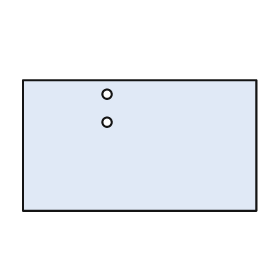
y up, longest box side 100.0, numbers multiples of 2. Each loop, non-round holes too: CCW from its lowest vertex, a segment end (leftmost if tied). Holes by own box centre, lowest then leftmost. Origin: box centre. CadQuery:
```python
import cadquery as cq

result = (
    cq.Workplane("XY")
    .moveTo(-50.0, -28.0)
    .lineTo(50.0, -28.0)
    .lineTo(50.0, 28.0)
    .lineTo(-50.0, 28.0)
    .close()
    .moveTo(-14.0, 10.0)
    .circle(2.0)
    .moveTo(-14.0, 22.0)
    .circle(2.0)
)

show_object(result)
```